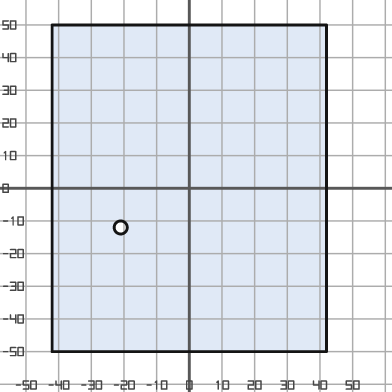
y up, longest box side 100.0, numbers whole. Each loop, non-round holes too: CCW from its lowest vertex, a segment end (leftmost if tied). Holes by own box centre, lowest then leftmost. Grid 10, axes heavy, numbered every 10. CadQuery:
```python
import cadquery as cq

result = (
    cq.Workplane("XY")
    .moveTo(-42.0, -50.0)
    .lineTo(42.0, -50.0)
    .lineTo(42.0, 50.0)
    .lineTo(-42.0, 50.0)
    .close()
    .moveTo(-21.0, -12.0)
    .circle(2.0)
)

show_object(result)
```